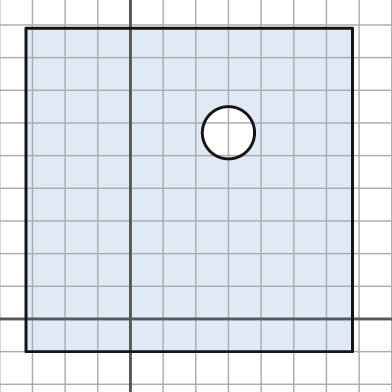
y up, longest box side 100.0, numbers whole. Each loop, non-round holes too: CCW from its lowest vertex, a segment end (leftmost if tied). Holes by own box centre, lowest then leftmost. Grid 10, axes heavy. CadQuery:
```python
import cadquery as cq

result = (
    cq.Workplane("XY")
    .moveTo(-32.0, -10.0)
    .lineTo(68.0, -10.0)
    .lineTo(68.0, 89.0)
    .lineTo(-32.0, 89.0)
    .close()
    .moveTo(30.0, 57.0)
    .circle(8.0)
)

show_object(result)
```